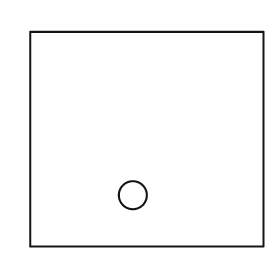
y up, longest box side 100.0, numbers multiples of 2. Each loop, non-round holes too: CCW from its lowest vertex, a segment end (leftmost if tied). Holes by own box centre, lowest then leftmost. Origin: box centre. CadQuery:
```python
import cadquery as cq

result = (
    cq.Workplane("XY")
    .moveTo(-50.0, -46.0)
    .lineTo(50.0, -46.0)
    .lineTo(50.0, 46.0)
    .lineTo(-50.0, 46.0)
    .close()
    .moveTo(-6.0, -24.0)
    .circle(6.0)
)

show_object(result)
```